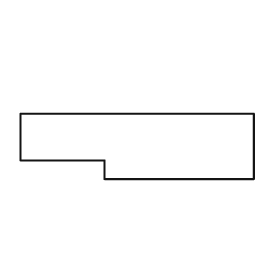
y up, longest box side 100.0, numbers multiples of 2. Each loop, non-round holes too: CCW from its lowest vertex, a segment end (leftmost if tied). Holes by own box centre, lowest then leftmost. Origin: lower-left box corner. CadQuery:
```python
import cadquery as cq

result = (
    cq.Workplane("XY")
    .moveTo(36.0, 0.0)
    .lineTo(100.0, 0.0)
    .lineTo(100.0, 28.0)
    .lineTo(0.0, 28.0)
    .lineTo(0.0, 8.0)
    .lineTo(36.0, 8.0)
    .close()
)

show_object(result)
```